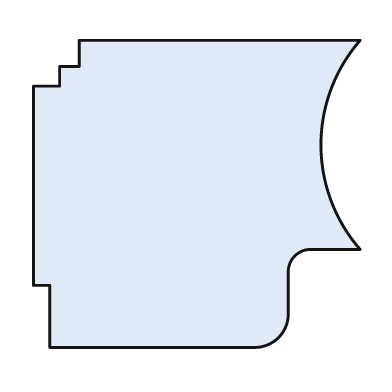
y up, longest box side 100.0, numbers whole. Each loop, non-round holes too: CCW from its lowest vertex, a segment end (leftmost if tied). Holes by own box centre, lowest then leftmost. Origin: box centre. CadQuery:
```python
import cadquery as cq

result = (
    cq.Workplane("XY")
    .moveTo(-45.0, -47.0)
    .lineTo(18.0, -47.0)
    .threePointArc((25.0, -44.0), (28.0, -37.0))
    .lineTo(28.0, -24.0)
    .threePointArc((30.0, -19.0), (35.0, -17.0))
    .lineTo(50.0, -17.0)
    .threePointArc((38.0, 15.0), (50.0, 47.0))
    .lineTo(-36.0, 47.0)
    .lineTo(-36.0, 39.0)
    .lineTo(-42.0, 39.0)
    .lineTo(-42.0, 33.0)
    .lineTo(-50.0, 33.0)
    .lineTo(-50.0, -28.0)
    .lineTo(-45.0, -28.0)
    .close()
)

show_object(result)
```